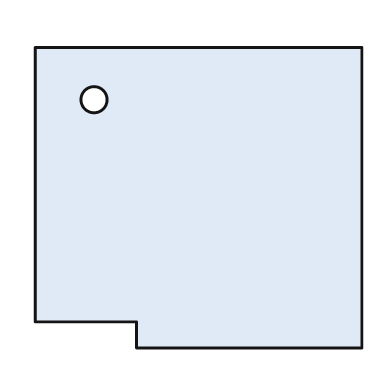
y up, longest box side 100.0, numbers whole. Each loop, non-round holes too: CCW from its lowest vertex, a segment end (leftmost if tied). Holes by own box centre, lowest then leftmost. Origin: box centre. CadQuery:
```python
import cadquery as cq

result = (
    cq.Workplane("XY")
    .moveTo(-19.0, -46.0)
    .lineTo(50.0, -46.0)
    .lineTo(50.0, 46.0)
    .lineTo(-50.0, 46.0)
    .lineTo(-50.0, -38.0)
    .lineTo(-19.0, -38.0)
    .close()
    .moveTo(-32.0, 30.0)
    .circle(4.0)
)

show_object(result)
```